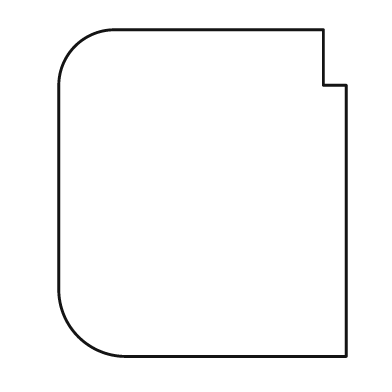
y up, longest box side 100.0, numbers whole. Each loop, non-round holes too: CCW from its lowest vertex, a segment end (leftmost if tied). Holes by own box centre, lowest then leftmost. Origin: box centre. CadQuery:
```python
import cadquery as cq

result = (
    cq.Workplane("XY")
    .moveTo(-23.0, -50.0)
    .lineTo(44.0, -50.0)
    .lineTo(44.0, 33.0)
    .lineTo(37.0, 33.0)
    .lineTo(37.0, 50.0)
    .lineTo(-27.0, 50.0)
    .threePointArc((-39.0, 45.0), (-44.0, 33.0))
    .lineTo(-44.0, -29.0)
    .threePointArc((-38.0, -44.0), (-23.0, -50.0))
    .close()
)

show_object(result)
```